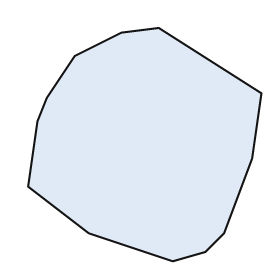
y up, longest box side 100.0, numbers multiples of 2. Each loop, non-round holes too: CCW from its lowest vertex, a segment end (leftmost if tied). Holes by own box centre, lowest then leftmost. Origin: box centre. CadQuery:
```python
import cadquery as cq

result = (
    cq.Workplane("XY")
    .moveTo(12.0, -50.0)
    .lineTo(26.0, -46.0)
    .lineTo(34.0, -38.0)
    .lineTo(46.0, -6.0)
    .lineTo(50.0, 22.0)
    .lineTo(6.0, 50.0)
    .lineTo(-10.0, 48.0)
    .lineTo(-30.0, 38.0)
    .lineTo(-42.0, 20.0)
    .lineTo(-46.0, 10.0)
    .lineTo(-50.0, -18.0)
    .lineTo(-24.0, -38.0)
    .close()
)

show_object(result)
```